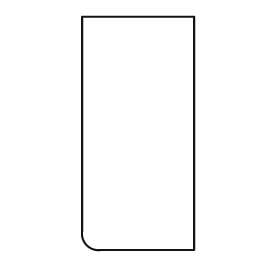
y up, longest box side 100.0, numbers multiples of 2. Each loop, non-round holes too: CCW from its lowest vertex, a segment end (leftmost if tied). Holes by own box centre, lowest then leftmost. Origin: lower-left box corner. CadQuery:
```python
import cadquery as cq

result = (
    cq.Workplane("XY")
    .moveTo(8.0, 0.0)
    .lineTo(48.0, 0.0)
    .lineTo(48.0, 100.0)
    .lineTo(0.0, 100.0)
    .lineTo(0.0, 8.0)
    .threePointArc((2.0, 2.0), (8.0, 0.0))
    .close()
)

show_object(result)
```